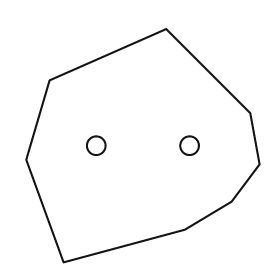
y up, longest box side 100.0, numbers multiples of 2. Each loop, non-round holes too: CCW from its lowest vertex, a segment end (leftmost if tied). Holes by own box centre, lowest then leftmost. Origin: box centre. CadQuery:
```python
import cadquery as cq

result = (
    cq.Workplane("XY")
    .moveTo(-34.0, -50.0)
    .lineTo(18.0, -36.0)
    .lineTo(38.0, -24.0)
    .lineTo(50.0, -8.0)
    .lineTo(46.0, 14.0)
    .lineTo(10.0, 50.0)
    .lineTo(-40.0, 28.0)
    .lineTo(-50.0, -6.0)
    .close()
    .moveTo(-20.0, 0.0)
    .circle(4.0)
    .moveTo(20.0, 0.0)
    .circle(4.0)
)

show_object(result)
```